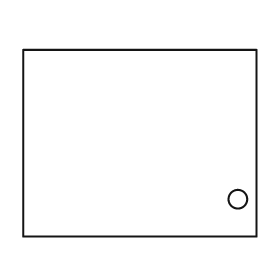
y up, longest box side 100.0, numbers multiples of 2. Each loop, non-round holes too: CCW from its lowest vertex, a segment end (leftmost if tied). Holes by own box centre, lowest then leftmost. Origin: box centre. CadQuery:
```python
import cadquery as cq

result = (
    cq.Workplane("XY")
    .moveTo(-50.0, -40.0)
    .lineTo(50.0, -40.0)
    .lineTo(50.0, 40.0)
    .lineTo(-50.0, 40.0)
    .close()
    .moveTo(42.0, -24.0)
    .circle(4.0)
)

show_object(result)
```